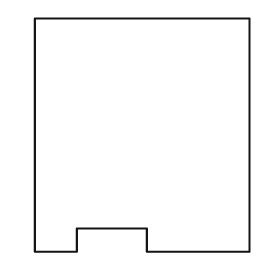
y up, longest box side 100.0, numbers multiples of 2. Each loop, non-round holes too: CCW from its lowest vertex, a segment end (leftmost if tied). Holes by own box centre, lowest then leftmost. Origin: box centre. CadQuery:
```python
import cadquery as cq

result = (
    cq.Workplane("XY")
    .moveTo(-46.0, -50.0)
    .lineTo(-28.0, -50.0)
    .lineTo(-28.0, -40.0)
    .lineTo(2.0, -40.0)
    .lineTo(2.0, -50.0)
    .lineTo(46.0, -50.0)
    .lineTo(46.0, 50.0)
    .lineTo(-46.0, 50.0)
    .close()
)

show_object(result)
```